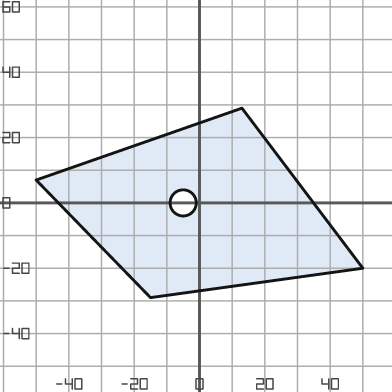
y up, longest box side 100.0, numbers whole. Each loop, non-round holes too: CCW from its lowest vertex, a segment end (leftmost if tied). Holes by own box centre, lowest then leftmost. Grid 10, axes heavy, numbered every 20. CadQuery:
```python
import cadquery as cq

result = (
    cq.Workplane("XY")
    .moveTo(-15.0, -29.0)
    .lineTo(50.0, -20.0)
    .lineTo(13.0, 29.0)
    .lineTo(-50.0, 7.0)
    .close()
    .moveTo(-5.0, 0.0)
    .circle(4.0)
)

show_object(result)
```